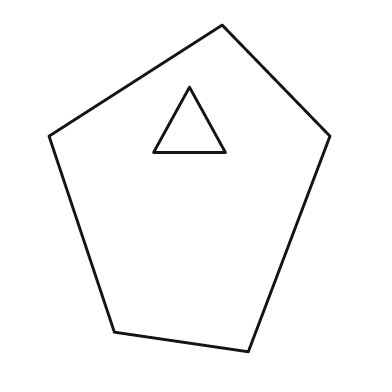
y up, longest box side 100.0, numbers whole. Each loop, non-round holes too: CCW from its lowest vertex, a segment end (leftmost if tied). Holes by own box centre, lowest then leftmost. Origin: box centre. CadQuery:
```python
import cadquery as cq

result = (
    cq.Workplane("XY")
    .moveTo(18.0, -50.0)
    .lineTo(43.0, 16.0)
    .lineTo(10.0, 50.0)
    .lineTo(-43.0, 16.0)
    .lineTo(-23.0, -44.0)
    .close()
    .moveTo(-11.0, 11.0)
    .lineTo(11.0, 11.0)
    .lineTo(0.0, 31.0)
    .close()
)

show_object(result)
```